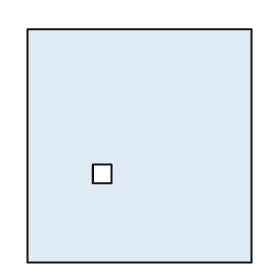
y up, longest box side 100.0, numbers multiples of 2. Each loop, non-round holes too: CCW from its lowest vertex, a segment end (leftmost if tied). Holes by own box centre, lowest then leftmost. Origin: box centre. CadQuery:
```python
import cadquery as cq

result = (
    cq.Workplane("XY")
    .moveTo(-48.0, -50.0)
    .lineTo(48.0, -50.0)
    .lineTo(48.0, 50.0)
    .lineTo(-48.0, 50.0)
    .close()
    .moveTo(-20.0, -16.0)
    .lineTo(-12.0, -16.0)
    .lineTo(-12.0, -8.0)
    .lineTo(-20.0, -8.0)
    .close()
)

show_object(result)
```